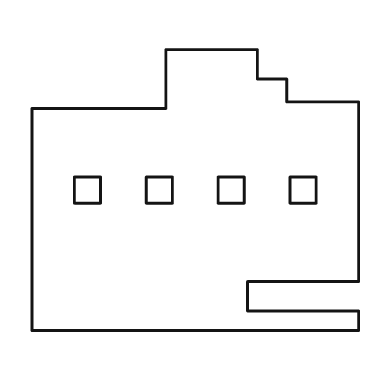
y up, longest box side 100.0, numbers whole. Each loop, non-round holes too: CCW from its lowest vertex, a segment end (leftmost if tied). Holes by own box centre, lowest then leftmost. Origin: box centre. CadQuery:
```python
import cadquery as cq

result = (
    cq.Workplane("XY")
    .moveTo(-50.0, -43.0)
    .lineTo(50.0, -43.0)
    .lineTo(50.0, -37.0)
    .lineTo(16.0, -37.0)
    .lineTo(16.0, -28.0)
    .lineTo(50.0, -28.0)
    .lineTo(50.0, 27.0)
    .lineTo(28.0, 27.0)
    .lineTo(28.0, 34.0)
    .lineTo(19.0, 34.0)
    .lineTo(19.0, 43.0)
    .lineTo(-9.0, 43.0)
    .lineTo(-9.0, 25.0)
    .lineTo(-50.0, 25.0)
    .close()
    .moveTo(-37.0, -4.0)
    .lineTo(-29.0, -4.0)
    .lineTo(-29.0, 4.0)
    .lineTo(-37.0, 4.0)
    .close()
    .moveTo(-15.0, -4.0)
    .lineTo(-7.0, -4.0)
    .lineTo(-7.0, 4.0)
    .lineTo(-15.0, 4.0)
    .close()
    .moveTo(7.0, -4.0)
    .lineTo(15.0, -4.0)
    .lineTo(15.0, 4.0)
    .lineTo(7.0, 4.0)
    .close()
    .moveTo(29.0, -4.0)
    .lineTo(37.0, -4.0)
    .lineTo(37.0, 4.0)
    .lineTo(29.0, 4.0)
    .close()
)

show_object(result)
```